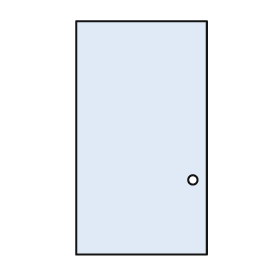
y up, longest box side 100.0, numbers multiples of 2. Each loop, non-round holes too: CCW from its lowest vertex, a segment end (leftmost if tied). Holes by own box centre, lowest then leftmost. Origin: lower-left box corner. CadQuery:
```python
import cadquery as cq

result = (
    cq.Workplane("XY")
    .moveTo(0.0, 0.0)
    .lineTo(56.0, 0.0)
    .lineTo(56.0, 100.0)
    .lineTo(0.0, 100.0)
    .close()
    .moveTo(50.0, 32.0)
    .circle(2.0)
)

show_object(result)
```